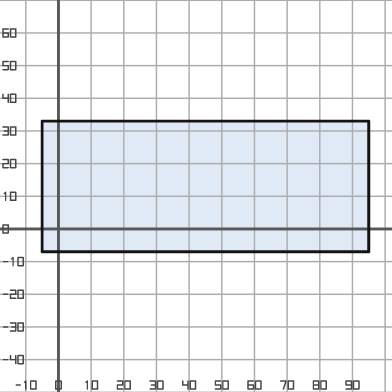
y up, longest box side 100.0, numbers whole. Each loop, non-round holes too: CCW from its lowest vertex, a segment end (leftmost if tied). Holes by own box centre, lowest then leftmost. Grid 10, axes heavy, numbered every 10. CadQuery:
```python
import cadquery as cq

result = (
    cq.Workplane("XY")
    .moveTo(-5.0, -7.0)
    .lineTo(95.0, -7.0)
    .lineTo(95.0, 33.0)
    .lineTo(-5.0, 33.0)
    .close()
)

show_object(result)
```